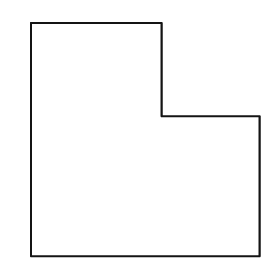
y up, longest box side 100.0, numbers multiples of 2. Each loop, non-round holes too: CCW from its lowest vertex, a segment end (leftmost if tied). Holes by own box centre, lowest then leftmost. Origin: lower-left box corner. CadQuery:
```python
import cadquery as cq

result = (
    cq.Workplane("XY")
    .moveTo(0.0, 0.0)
    .lineTo(98.0, 0.0)
    .lineTo(98.0, 60.0)
    .lineTo(56.0, 60.0)
    .lineTo(56.0, 100.0)
    .lineTo(0.0, 100.0)
    .close()
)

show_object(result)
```